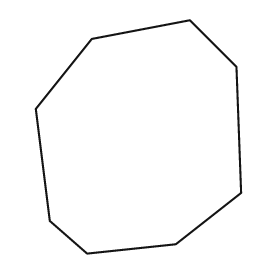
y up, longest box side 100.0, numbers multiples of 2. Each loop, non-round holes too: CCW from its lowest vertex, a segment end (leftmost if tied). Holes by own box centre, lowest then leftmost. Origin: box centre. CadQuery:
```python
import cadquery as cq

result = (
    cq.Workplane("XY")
    .moveTo(-22.0, -50.0)
    .lineTo(16.0, -46.0)
    .lineTo(44.0, -24.0)
    .lineTo(42.0, 30.0)
    .lineTo(22.0, 50.0)
    .lineTo(-20.0, 42.0)
    .lineTo(-44.0, 12.0)
    .lineTo(-38.0, -36.0)
    .close()
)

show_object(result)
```